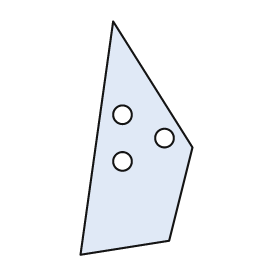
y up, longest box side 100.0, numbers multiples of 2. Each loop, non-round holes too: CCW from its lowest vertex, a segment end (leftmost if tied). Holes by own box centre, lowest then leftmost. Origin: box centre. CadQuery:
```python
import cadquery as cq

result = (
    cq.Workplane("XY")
    .moveTo(-24.0, -50.0)
    .lineTo(14.0, -44.0)
    .lineTo(24.0, -4.0)
    .lineTo(-10.0, 50.0)
    .close()
    .moveTo(-6.0, -10.0)
    .circle(4.0)
    .moveTo(12.0, 0.0)
    .circle(4.0)
    .moveTo(-6.0, 10.0)
    .circle(4.0)
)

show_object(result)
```